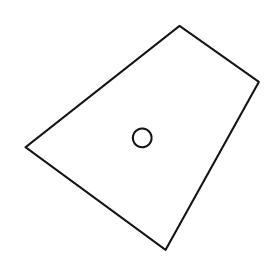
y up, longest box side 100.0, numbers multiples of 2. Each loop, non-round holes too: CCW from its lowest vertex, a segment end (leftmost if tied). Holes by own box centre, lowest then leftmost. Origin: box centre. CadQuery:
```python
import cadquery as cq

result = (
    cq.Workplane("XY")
    .moveTo(10.0, -48.0)
    .lineTo(50.0, 24.0)
    .lineTo(16.0, 48.0)
    .lineTo(-50.0, -4.0)
    .close()
    .moveTo(0.0, 0.0)
    .circle(4.0)
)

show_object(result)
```